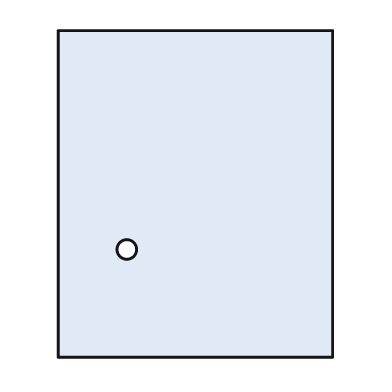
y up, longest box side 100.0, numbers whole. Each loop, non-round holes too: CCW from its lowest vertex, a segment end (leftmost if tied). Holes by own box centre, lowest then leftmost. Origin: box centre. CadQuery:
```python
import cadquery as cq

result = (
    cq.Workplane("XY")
    .moveTo(-42.0, -50.0)
    .lineTo(42.0, -50.0)
    .lineTo(42.0, 50.0)
    .lineTo(-42.0, 50.0)
    .close()
    .moveTo(-21.0, -17.0)
    .circle(3.0)
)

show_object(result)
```